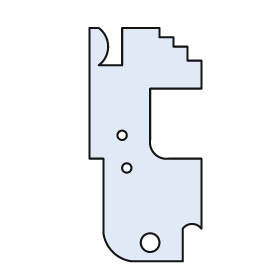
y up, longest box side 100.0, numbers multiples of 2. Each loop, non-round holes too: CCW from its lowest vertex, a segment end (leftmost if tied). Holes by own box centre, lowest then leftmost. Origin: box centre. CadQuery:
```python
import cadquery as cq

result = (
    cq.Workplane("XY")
    .moveTo(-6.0, -50.0)
    .lineTo(16.0, -50.0)
    .lineTo(16.0, -36.0)
    .threePointArc((20.0, -34.0), (24.0, -36.0))
    .lineTo(24.0, -6.0)
    .lineTo(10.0, -6.0)
    .threePointArc((4.0, -4.0), (2.0, 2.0))
    .lineTo(2.0, 24.0)
    .lineTo(24.0, 24.0)
    .lineTo(24.0, 36.0)
    .lineTo(18.0, 36.0)
    .lineTo(18.0, 42.0)
    .lineTo(12.0, 42.0)
    .lineTo(12.0, 46.0)
    .lineTo(6.0, 46.0)
    .lineTo(6.0, 50.0)
    .lineTo(-10.0, 50.0)
    .lineTo(-10.0, 34.0)
    .lineTo(-20.0, 34.0)
    .threePointArc((-16.0, 42.0), (-20.0, 50.0))
    .lineTo(-24.0, 50.0)
    .lineTo(-24.0, -6.0)
    .lineTo(-18.0, -6.0)
    .lineTo(-18.0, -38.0)
    .threePointArc((-14.0, -46.0), (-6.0, -50.0))
    .close()
    .moveTo(2.0, -42.0)
    .circle(4.0)
    .moveTo(-8.0, -10.0)
    .circle(2.0)
    .moveTo(-10.0, 4.0)
    .circle(2.0)
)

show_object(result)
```